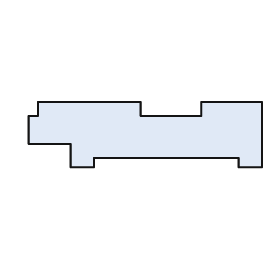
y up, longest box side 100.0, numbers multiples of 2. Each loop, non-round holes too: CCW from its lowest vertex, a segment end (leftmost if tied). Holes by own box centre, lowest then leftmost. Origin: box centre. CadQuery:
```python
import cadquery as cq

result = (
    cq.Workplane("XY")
    .moveTo(-32.0, -14.0)
    .lineTo(-22.0, -14.0)
    .lineTo(-22.0, -10.0)
    .lineTo(40.0, -10.0)
    .lineTo(40.0, -14.0)
    .lineTo(50.0, -14.0)
    .lineTo(50.0, 14.0)
    .lineTo(24.0, 14.0)
    .lineTo(24.0, 8.0)
    .lineTo(-2.0, 8.0)
    .lineTo(-2.0, 14.0)
    .lineTo(-46.0, 14.0)
    .lineTo(-46.0, 8.0)
    .lineTo(-50.0, 8.0)
    .lineTo(-50.0, -4.0)
    .lineTo(-32.0, -4.0)
    .close()
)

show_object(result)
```